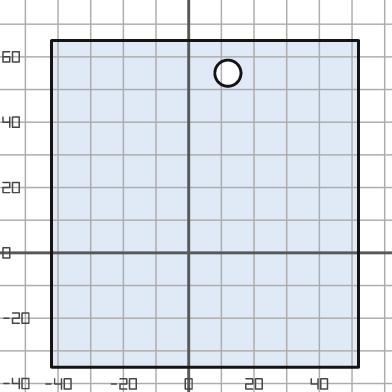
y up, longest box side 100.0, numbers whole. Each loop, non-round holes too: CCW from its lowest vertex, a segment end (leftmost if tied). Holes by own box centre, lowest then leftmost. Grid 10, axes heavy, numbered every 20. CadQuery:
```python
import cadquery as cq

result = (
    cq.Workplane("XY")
    .moveTo(-42.0, -35.0)
    .lineTo(52.0, -35.0)
    .lineTo(52.0, 65.0)
    .lineTo(-42.0, 65.0)
    .close()
    .moveTo(12.0, 55.0)
    .circle(4.0)
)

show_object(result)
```